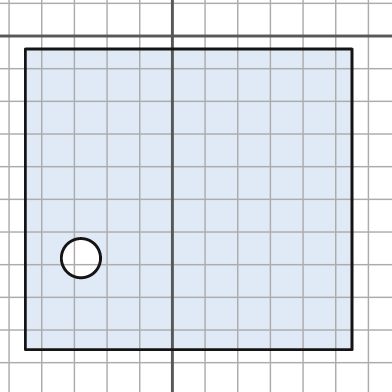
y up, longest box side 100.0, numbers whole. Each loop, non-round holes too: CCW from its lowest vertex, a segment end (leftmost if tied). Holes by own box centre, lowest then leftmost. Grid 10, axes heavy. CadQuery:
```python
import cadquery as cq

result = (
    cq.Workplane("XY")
    .moveTo(-45.0, -96.0)
    .lineTo(55.0, -96.0)
    .lineTo(55.0, -4.0)
    .lineTo(-45.0, -4.0)
    .close()
    .moveTo(-28.0, -68.0)
    .circle(6.0)
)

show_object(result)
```